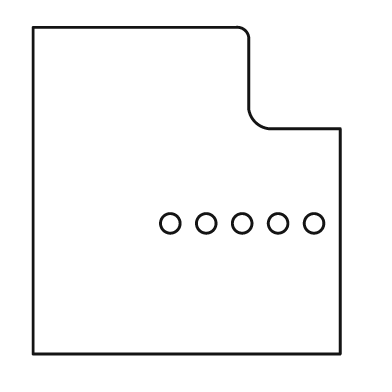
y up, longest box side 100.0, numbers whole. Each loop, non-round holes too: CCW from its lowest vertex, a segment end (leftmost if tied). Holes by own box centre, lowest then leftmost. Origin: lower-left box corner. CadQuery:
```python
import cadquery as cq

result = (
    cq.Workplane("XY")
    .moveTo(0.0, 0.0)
    .lineTo(94.0, 0.0)
    .lineTo(94.0, 69.0)
    .lineTo(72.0, 69.0)
    .threePointArc((68.0, 71.0), (66.0, 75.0))
    .lineTo(66.0, 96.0)
    .threePointArc((65.0, 99.0), (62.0, 100.0))
    .lineTo(0.0, 100.0)
    .close()
    .moveTo(42.0, 40.0)
    .circle(3.0)
    .moveTo(53.0, 40.0)
    .circle(3.0)
    .moveTo(64.0, 40.0)
    .circle(3.0)
    .moveTo(75.0, 40.0)
    .circle(3.0)
    .moveTo(86.0, 40.0)
    .circle(3.0)
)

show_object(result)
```